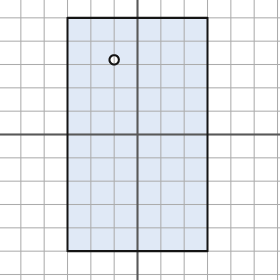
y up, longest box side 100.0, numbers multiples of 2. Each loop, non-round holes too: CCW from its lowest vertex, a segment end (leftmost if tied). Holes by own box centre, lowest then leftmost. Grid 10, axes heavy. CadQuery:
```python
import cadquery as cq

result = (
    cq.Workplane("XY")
    .moveTo(-30.0, -50.0)
    .lineTo(30.0, -50.0)
    .lineTo(30.0, 50.0)
    .lineTo(-30.0, 50.0)
    .close()
    .moveTo(-10.0, 32.0)
    .circle(2.0)
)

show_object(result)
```